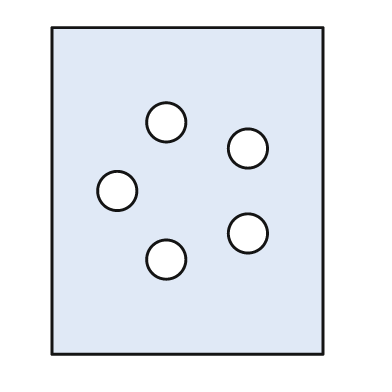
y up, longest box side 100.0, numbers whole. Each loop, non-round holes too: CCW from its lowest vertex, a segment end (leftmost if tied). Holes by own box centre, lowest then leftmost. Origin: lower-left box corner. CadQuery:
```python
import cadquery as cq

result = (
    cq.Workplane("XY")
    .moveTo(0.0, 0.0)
    .lineTo(83.0, 0.0)
    .lineTo(83.0, 100.0)
    .lineTo(0.0, 100.0)
    .close()
    .moveTo(35.0, 29.0)
    .circle(6.0)
    .moveTo(60.0, 37.0)
    .circle(6.0)
    .moveTo(20.0, 50.0)
    .circle(6.0)
    .moveTo(60.0, 63.0)
    .circle(6.0)
    .moveTo(35.0, 71.0)
    .circle(6.0)
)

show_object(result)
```